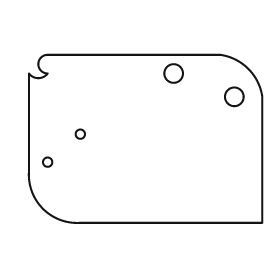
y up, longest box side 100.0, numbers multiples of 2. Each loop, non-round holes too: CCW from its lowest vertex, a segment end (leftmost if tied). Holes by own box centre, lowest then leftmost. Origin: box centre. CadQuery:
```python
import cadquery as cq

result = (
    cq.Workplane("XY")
    .moveTo(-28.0, -36.0)
    .lineTo(50.0, -36.0)
    .lineTo(50.0, 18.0)
    .threePointArc((44.0, 30.0), (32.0, 36.0))
    .lineTo(-42.0, 36.0)
    .threePointArc((-46.0, 32.0), (-42.0, 28.0))
    .threePointArc((-46.0, 26.0), (-50.0, 28.0))
    .lineTo(-50.0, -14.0)
    .threePointArc((-44.0, -30.0), (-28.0, -36.0))
    .close()
    .moveTo(-42.0, -10.0)
    .circle(2.0)
    .moveTo(-28.0, 2.0)
    .circle(2.0)
    .moveTo(38.0, 18.0)
    .circle(4.0)
    .moveTo(12.0, 28.0)
    .circle(4.0)
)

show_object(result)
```